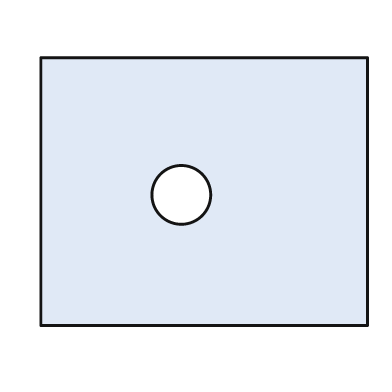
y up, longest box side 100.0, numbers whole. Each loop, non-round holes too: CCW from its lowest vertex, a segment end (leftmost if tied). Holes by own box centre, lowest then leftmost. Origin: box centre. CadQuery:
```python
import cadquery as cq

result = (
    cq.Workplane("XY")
    .moveTo(-50.0, -41.0)
    .lineTo(50.0, -41.0)
    .lineTo(50.0, 41.0)
    .lineTo(-50.0, 41.0)
    .close()
    .moveTo(-7.0, -1.0)
    .circle(9.0)
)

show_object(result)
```